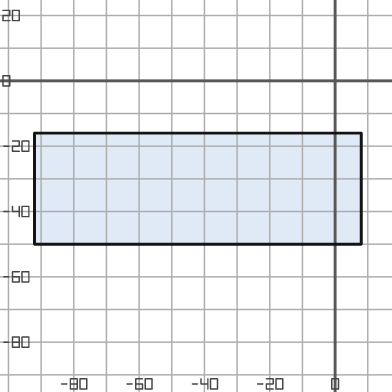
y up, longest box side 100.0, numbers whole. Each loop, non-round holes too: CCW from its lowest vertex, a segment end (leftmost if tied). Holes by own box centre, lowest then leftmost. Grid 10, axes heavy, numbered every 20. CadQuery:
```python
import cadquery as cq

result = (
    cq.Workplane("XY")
    .moveTo(-92.0, -50.0)
    .lineTo(8.0, -50.0)
    .lineTo(8.0, -16.0)
    .lineTo(-92.0, -16.0)
    .close()
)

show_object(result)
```